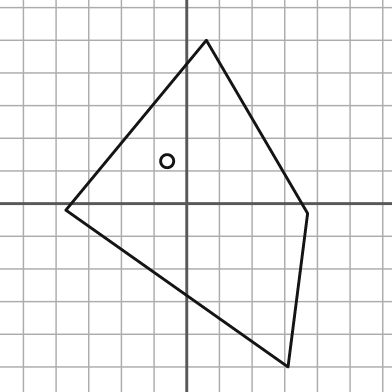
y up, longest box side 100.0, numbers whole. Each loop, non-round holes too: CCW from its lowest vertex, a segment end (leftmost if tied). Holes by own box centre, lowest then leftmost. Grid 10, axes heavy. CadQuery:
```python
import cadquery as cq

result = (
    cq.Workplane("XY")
    .moveTo(31.0, -50.0)
    .lineTo(37.0, -3.0)
    .lineTo(6.0, 50.0)
    .lineTo(-37.0, -2.0)
    .close()
    .moveTo(-6.0, 13.0)
    .circle(2.0)
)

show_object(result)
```